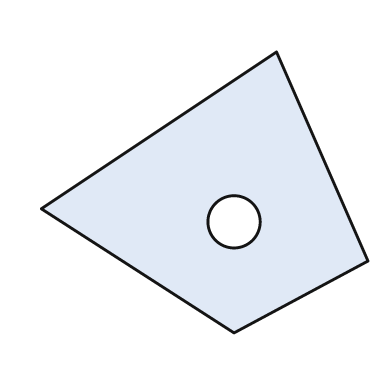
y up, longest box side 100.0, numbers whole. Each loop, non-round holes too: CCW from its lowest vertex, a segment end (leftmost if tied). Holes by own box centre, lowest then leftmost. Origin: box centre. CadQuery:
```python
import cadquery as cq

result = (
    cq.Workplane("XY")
    .moveTo(9.0, -43.0)
    .lineTo(50.0, -21.0)
    .lineTo(22.0, 43.0)
    .lineTo(-50.0, -5.0)
    .close()
    .moveTo(9.0, -9.0)
    .circle(8.0)
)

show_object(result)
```